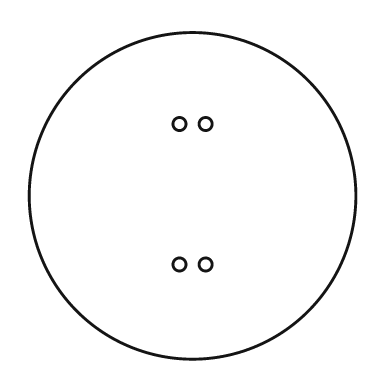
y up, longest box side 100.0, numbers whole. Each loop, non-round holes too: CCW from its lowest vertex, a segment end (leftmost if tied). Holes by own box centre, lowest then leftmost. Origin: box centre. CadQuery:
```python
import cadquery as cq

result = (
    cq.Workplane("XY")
    .moveTo(0.0, 0.0)
    .circle(50.0)
    .moveTo(-4.0, -21.0)
    .circle(2.0)
    .moveTo(4.0, -21.0)
    .circle(2.0)
    .moveTo(-4.0, 22.0)
    .circle(2.0)
    .moveTo(4.0, 22.0)
    .circle(2.0)
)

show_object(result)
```